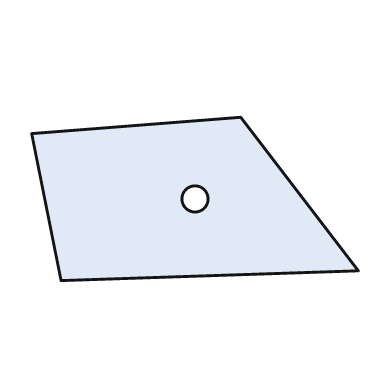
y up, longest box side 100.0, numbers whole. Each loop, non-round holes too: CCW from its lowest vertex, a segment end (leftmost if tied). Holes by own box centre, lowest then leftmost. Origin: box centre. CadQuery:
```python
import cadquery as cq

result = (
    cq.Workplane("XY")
    .moveTo(-41.0, -25.0)
    .lineTo(50.0, -22.0)
    .lineTo(14.0, 25.0)
    .lineTo(-50.0, 20.0)
    .close()
    .moveTo(0.0, 0.0)
    .circle(4.0)
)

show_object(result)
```